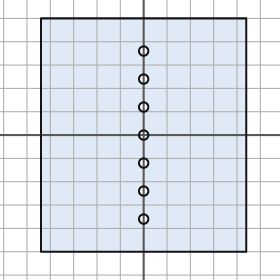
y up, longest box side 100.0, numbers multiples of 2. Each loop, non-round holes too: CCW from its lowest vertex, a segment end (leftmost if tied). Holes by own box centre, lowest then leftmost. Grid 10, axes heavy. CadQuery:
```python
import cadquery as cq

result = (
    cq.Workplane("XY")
    .moveTo(-44.0, -50.0)
    .lineTo(44.0, -50.0)
    .lineTo(44.0, 50.0)
    .lineTo(-44.0, 50.0)
    .close()
    .moveTo(0.0, -36.0)
    .circle(2.0)
    .moveTo(0.0, -24.0)
    .circle(2.0)
    .moveTo(0.0, -12.0)
    .circle(2.0)
    .moveTo(0.0, 0.0)
    .circle(2.0)
    .moveTo(0.0, 12.0)
    .circle(2.0)
    .moveTo(0.0, 24.0)
    .circle(2.0)
    .moveTo(0.0, 36.0)
    .circle(2.0)
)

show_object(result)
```